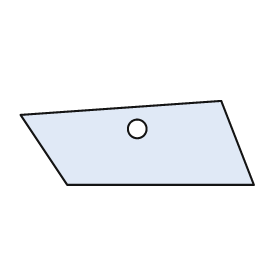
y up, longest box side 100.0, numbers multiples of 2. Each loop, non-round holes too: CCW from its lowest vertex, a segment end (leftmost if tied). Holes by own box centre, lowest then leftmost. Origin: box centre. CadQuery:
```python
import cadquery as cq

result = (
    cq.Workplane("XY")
    .moveTo(-30.0, -18.0)
    .lineTo(50.0, -18.0)
    .lineTo(36.0, 18.0)
    .lineTo(-50.0, 12.0)
    .close()
    .moveTo(0.0, 6.0)
    .circle(4.0)
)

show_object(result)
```